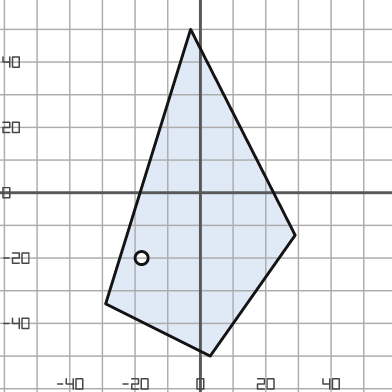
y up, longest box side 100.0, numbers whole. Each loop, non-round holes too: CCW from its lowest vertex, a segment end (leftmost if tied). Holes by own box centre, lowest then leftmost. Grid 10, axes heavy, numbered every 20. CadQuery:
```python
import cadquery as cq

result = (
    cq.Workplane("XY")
    .moveTo(3.0, -50.0)
    .lineTo(29.0, -13.0)
    .lineTo(-3.0, 50.0)
    .lineTo(-29.0, -34.0)
    .close()
    .moveTo(-18.0, -20.0)
    .circle(2.0)
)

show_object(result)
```